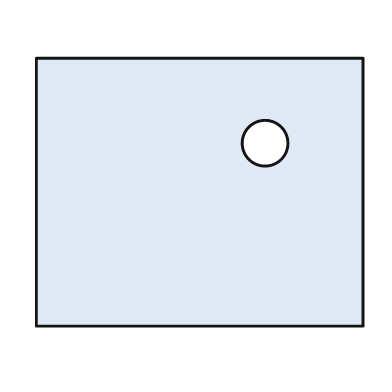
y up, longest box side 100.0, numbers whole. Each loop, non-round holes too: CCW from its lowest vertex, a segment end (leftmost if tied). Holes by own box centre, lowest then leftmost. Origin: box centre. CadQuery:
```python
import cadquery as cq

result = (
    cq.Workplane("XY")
    .moveTo(-50.0, -41.0)
    .lineTo(50.0, -41.0)
    .lineTo(50.0, 41.0)
    .lineTo(-50.0, 41.0)
    .close()
    .moveTo(20.0, 15.0)
    .circle(7.0)
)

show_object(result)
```